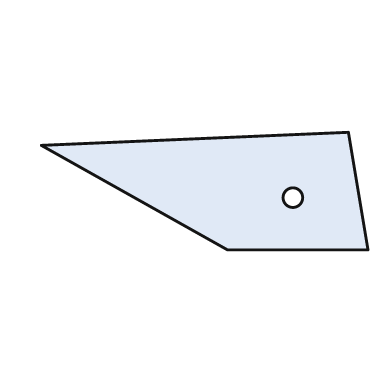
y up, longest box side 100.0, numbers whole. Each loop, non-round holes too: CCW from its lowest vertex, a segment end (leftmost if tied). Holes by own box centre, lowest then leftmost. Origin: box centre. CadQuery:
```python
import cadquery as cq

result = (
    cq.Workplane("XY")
    .moveTo(7.0, -18.0)
    .lineTo(50.0, -18.0)
    .lineTo(44.0, 18.0)
    .lineTo(-50.0, 14.0)
    .close()
    .moveTo(27.0, -2.0)
    .circle(3.0)
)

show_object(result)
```